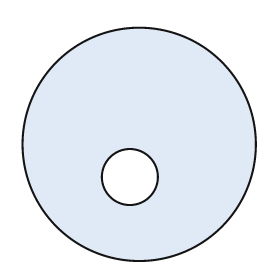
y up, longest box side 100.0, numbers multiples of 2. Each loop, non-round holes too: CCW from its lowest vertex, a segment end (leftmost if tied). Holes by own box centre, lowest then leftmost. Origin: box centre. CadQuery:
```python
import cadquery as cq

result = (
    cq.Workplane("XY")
    .moveTo(0.0, 0.0)
    .circle(50.0)
    .moveTo(-4.0, -14.0)
    .circle(12.0)
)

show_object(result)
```